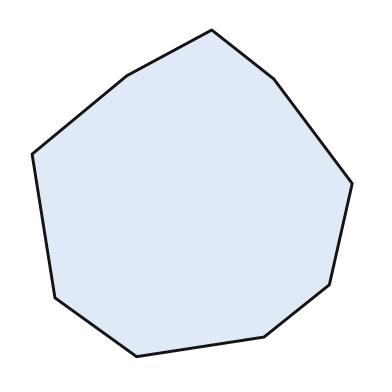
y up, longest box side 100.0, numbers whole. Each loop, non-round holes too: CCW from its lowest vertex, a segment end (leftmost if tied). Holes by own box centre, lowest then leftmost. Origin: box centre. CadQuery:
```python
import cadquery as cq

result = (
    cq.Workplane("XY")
    .moveTo(-17.0, -50.0)
    .lineTo(22.0, -44.0)
    .lineTo(42.0, -28.0)
    .lineTo(49.0, 3.0)
    .lineTo(25.0, 35.0)
    .lineTo(6.0, 50.0)
    .lineTo(-20.0, 36.0)
    .lineTo(-49.0, 12.0)
    .lineTo(-42.0, -32.0)
    .close()
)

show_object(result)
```